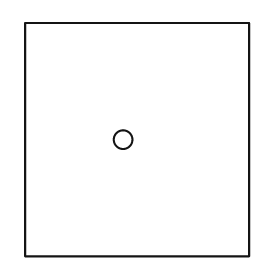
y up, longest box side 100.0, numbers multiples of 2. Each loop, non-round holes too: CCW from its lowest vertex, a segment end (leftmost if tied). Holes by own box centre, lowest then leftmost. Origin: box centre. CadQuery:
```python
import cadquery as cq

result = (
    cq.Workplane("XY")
    .moveTo(-48.0, -50.0)
    .lineTo(48.0, -50.0)
    .lineTo(48.0, 50.0)
    .lineTo(-48.0, 50.0)
    .close()
    .moveTo(-6.0, 0.0)
    .circle(4.0)
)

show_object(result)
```